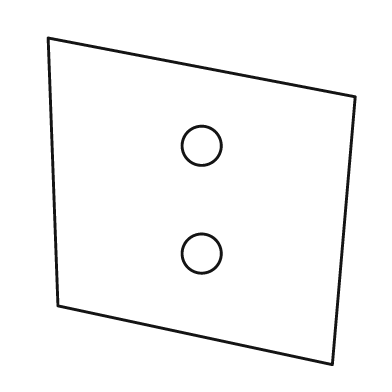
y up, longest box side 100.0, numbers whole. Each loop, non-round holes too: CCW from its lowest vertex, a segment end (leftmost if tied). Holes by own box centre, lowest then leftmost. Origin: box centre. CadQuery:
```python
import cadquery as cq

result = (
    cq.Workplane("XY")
    .moveTo(40.0, -50.0)
    .lineTo(47.0, 32.0)
    .lineTo(-47.0, 50.0)
    .lineTo(-44.0, -32.0)
    .close()
    .moveTo(0.0, -16.0)
    .circle(6.0)
    .moveTo(0.0, 17.0)
    .circle(6.0)
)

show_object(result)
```